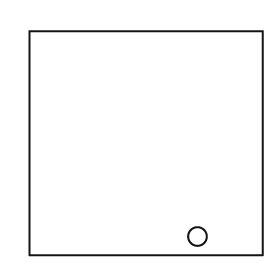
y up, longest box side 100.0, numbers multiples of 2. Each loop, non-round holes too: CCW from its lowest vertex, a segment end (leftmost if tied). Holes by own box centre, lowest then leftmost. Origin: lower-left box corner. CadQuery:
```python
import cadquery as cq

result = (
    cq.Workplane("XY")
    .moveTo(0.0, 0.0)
    .lineTo(100.0, 0.0)
    .lineTo(100.0, 96.0)
    .lineTo(0.0, 96.0)
    .close()
    .moveTo(72.0, 8.0)
    .circle(4.0)
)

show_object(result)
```